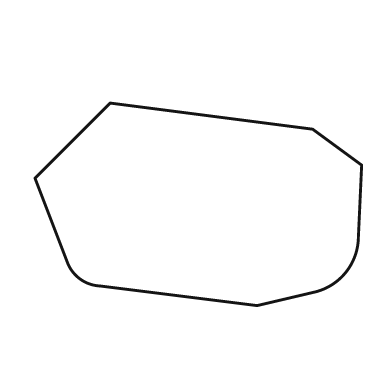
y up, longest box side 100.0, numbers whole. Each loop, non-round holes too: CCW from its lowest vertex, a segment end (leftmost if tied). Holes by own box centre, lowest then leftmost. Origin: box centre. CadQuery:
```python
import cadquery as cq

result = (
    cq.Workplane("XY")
    .moveTo(18.0, -31.0)
    .lineTo(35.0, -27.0)
    .threePointArc((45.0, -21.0), (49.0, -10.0))
    .lineTo(50.0, 12.0)
    .lineTo(35.0, 23.0)
    .lineTo(-27.0, 31.0)
    .lineTo(-50.0, 8.0)
    .lineTo(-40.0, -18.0)
    .threePointArc((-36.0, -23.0), (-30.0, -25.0))
    .close()
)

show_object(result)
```